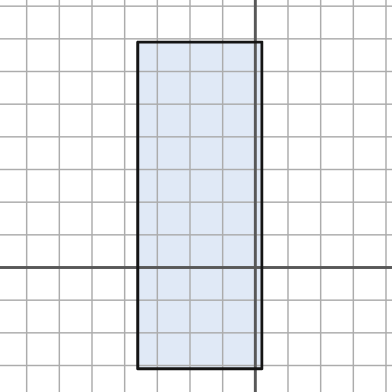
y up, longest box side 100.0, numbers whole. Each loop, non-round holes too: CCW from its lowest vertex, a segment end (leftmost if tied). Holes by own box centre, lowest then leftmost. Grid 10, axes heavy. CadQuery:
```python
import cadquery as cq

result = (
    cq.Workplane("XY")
    .moveTo(-36.0, -31.0)
    .lineTo(2.0, -31.0)
    .lineTo(2.0, 69.0)
    .lineTo(-36.0, 69.0)
    .close()
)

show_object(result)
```